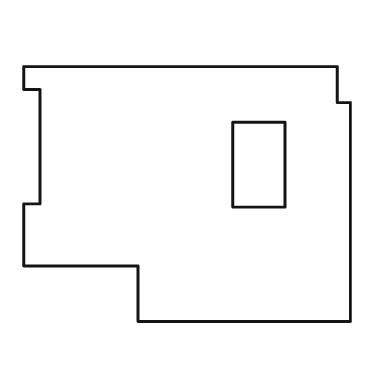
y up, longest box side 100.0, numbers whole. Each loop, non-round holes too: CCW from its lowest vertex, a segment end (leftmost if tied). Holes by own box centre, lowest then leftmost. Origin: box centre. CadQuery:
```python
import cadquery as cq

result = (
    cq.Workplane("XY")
    .moveTo(-15.0, -39.0)
    .lineTo(50.0, -39.0)
    .lineTo(50.0, 28.0)
    .lineTo(46.0, 28.0)
    .lineTo(46.0, 39.0)
    .lineTo(-50.0, 39.0)
    .lineTo(-50.0, 32.0)
    .lineTo(-45.0, 32.0)
    .lineTo(-45.0, -3.0)
    .lineTo(-50.0, -3.0)
    .lineTo(-50.0, -22.0)
    .lineTo(-15.0, -22.0)
    .close()
    .moveTo(14.0, -4.0)
    .lineTo(30.0, -4.0)
    .lineTo(30.0, 22.0)
    .lineTo(14.0, 22.0)
    .close()
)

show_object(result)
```